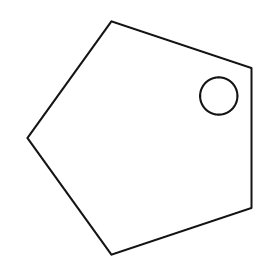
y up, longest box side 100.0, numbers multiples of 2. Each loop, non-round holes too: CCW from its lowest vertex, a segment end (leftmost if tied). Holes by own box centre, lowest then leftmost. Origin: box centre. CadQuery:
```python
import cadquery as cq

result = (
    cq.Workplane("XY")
    .moveTo(-12.0, -50.0)
    .lineTo(48.0, -30.0)
    .lineTo(48.0, 30.0)
    .lineTo(-12.0, 50.0)
    .lineTo(-48.0, 0.0)
    .close()
    .moveTo(34.0, 18.0)
    .circle(8.0)
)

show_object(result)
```